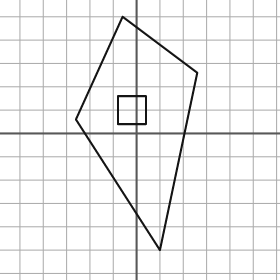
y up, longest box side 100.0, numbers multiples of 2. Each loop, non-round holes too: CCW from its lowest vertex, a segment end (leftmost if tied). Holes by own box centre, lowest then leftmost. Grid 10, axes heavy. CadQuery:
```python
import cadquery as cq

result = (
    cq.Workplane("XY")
    .moveTo(10.0, -50.0)
    .lineTo(26.0, 26.0)
    .lineTo(-6.0, 50.0)
    .lineTo(-26.0, 6.0)
    .close()
    .moveTo(-8.0, 4.0)
    .lineTo(4.0, 4.0)
    .lineTo(4.0, 16.0)
    .lineTo(-8.0, 16.0)
    .close()
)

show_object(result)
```